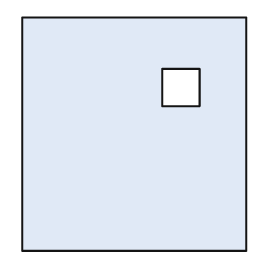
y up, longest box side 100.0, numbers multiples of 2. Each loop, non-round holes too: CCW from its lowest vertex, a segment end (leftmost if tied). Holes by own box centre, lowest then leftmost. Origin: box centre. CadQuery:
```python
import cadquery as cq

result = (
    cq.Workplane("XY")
    .moveTo(-48.0, -50.0)
    .lineTo(48.0, -50.0)
    .lineTo(48.0, 50.0)
    .lineTo(-48.0, 50.0)
    .close()
    .moveTo(12.0, 12.0)
    .lineTo(28.0, 12.0)
    .lineTo(28.0, 28.0)
    .lineTo(12.0, 28.0)
    .close()
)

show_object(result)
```